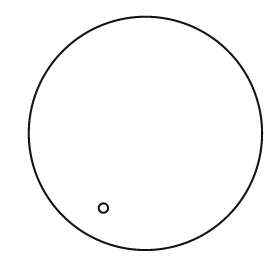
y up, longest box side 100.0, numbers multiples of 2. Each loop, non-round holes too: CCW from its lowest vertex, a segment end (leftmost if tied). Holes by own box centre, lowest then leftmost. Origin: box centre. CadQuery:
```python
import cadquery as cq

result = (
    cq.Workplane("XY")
    .moveTo(0.0, 0.0)
    .circle(50.0)
    .moveTo(-18.0, -32.0)
    .circle(2.0)
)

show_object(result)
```